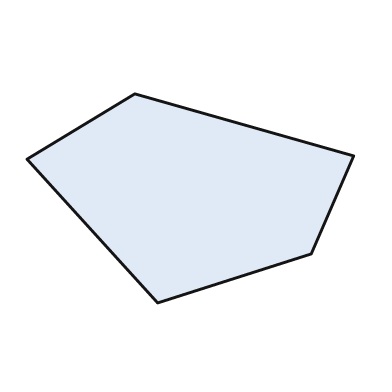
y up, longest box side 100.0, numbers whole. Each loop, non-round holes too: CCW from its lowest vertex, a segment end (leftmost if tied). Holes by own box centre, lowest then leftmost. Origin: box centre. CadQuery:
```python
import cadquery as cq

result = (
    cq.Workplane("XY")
    .moveTo(-10.0, -32.0)
    .lineTo(37.0, -17.0)
    .lineTo(50.0, 13.0)
    .lineTo(-17.0, 32.0)
    .lineTo(-50.0, 12.0)
    .close()
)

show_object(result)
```